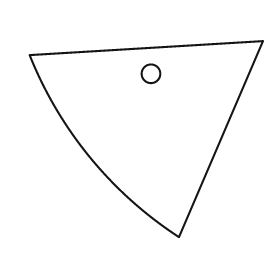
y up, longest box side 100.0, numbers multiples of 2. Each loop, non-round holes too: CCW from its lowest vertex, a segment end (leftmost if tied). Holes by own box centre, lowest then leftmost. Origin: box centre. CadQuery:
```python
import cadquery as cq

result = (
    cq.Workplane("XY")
    .moveTo(14.0, -42.0)
    .lineTo(50.0, 42.0)
    .lineTo(-50.0, 36.0)
    .threePointArc((-24.0, -8.0), (14.0, -42.0))
    .close()
    .moveTo(2.0, 28.0)
    .circle(4.0)
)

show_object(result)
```